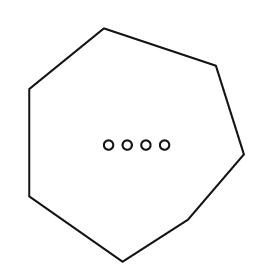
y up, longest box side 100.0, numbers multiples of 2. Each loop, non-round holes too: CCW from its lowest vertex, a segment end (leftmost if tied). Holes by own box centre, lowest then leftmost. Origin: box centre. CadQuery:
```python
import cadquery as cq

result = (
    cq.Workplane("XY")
    .moveTo(-6.0, -50.0)
    .lineTo(22.0, -32.0)
    .lineTo(46.0, -4.0)
    .lineTo(34.0, 34.0)
    .lineTo(-14.0, 50.0)
    .lineTo(-46.0, 24.0)
    .lineTo(-46.0, -22.0)
    .close()
    .moveTo(-12.0, 0.0)
    .circle(2.0)
    .moveTo(-4.0, 0.0)
    .circle(2.0)
    .moveTo(4.0, 0.0)
    .circle(2.0)
    .moveTo(12.0, 0.0)
    .circle(2.0)
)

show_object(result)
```